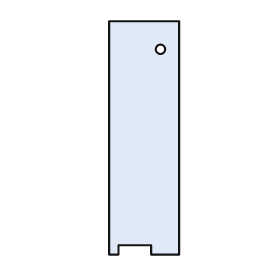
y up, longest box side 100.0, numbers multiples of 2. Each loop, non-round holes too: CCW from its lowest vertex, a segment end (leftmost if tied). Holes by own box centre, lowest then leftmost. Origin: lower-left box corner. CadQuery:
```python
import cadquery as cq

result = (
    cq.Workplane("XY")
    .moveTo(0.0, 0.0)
    .lineTo(4.0, 0.0)
    .lineTo(4.0, 4.0)
    .lineTo(18.0, 4.0)
    .lineTo(18.0, 0.0)
    .lineTo(30.0, 0.0)
    .lineTo(30.0, 100.0)
    .lineTo(0.0, 100.0)
    .close()
    .moveTo(22.0, 88.0)
    .circle(2.0)
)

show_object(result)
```